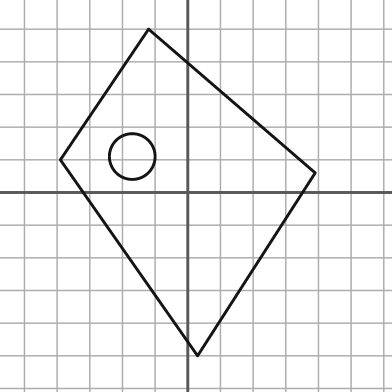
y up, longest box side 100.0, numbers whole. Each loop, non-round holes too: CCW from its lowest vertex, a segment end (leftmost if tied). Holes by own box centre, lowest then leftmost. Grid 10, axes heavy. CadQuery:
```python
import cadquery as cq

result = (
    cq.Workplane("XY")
    .moveTo(3.0, -50.0)
    .lineTo(39.0, 6.0)
    .lineTo(-12.0, 50.0)
    .lineTo(-39.0, 10.0)
    .close()
    .moveTo(-17.0, 11.0)
    .circle(7.0)
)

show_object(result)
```